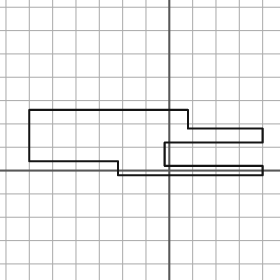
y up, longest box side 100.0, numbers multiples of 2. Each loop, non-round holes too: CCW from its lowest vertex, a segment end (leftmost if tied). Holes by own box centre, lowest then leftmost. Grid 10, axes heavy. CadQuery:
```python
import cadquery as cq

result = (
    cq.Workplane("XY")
    .moveTo(-22.0, -2.0)
    .lineTo(40.0, -2.0)
    .lineTo(40.0, 2.0)
    .lineTo(-2.0, 2.0)
    .lineTo(-2.0, 12.0)
    .lineTo(40.0, 12.0)
    .lineTo(40.0, 18.0)
    .lineTo(8.0, 18.0)
    .lineTo(8.0, 26.0)
    .lineTo(-60.0, 26.0)
    .lineTo(-60.0, 4.0)
    .lineTo(-22.0, 4.0)
    .close()
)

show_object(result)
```